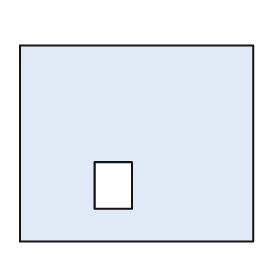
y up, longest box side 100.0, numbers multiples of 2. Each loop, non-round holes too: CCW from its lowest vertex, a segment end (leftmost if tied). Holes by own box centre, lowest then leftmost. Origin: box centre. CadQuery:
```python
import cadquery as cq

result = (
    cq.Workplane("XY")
    .moveTo(-50.0, -42.0)
    .lineTo(50.0, -42.0)
    .lineTo(50.0, 42.0)
    .lineTo(-50.0, 42.0)
    .close()
    .moveTo(-18.0, -28.0)
    .lineTo(-2.0, -28.0)
    .lineTo(-2.0, -8.0)
    .lineTo(-18.0, -8.0)
    .close()
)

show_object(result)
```